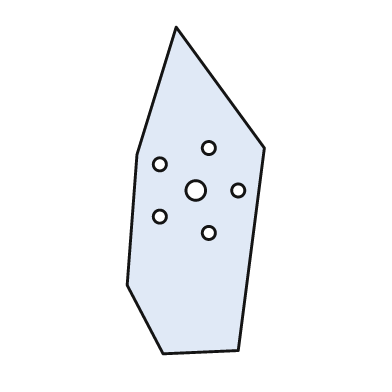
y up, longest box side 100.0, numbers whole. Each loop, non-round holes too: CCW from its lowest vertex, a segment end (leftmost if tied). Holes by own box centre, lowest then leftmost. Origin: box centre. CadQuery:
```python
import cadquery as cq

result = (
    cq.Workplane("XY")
    .moveTo(-10.0, -50.0)
    .lineTo(13.0, -49.0)
    .lineTo(21.0, 13.0)
    .lineTo(-6.0, 50.0)
    .lineTo(-18.0, 11.0)
    .lineTo(-21.0, -29.0)
    .close()
    .moveTo(4.0, -13.0)
    .circle(2.0)
    .moveTo(-11.0, -8.0)
    .circle(2.0)
    .moveTo(0.0, 0.0)
    .circle(3.0)
    .moveTo(13.0, 0.0)
    .circle(2.0)
    .moveTo(-11.0, 8.0)
    .circle(2.0)
    .moveTo(4.0, 13.0)
    .circle(2.0)
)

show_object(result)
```